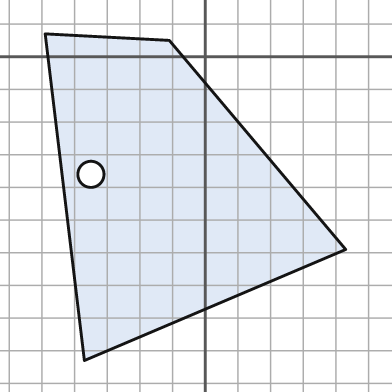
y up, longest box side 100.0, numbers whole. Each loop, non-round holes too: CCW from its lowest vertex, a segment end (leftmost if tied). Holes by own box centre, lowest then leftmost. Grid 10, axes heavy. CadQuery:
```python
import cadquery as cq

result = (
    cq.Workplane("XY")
    .moveTo(-37.0, -93.0)
    .lineTo(43.0, -59.0)
    .lineTo(-11.0, 5.0)
    .lineTo(-49.0, 7.0)
    .close()
    .moveTo(-35.0, -36.0)
    .circle(4.0)
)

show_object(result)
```